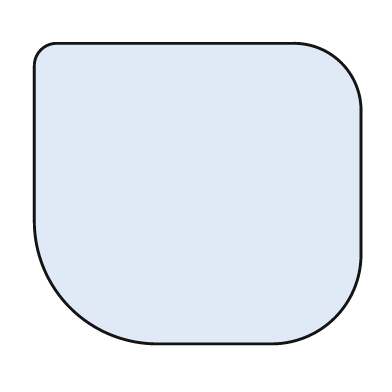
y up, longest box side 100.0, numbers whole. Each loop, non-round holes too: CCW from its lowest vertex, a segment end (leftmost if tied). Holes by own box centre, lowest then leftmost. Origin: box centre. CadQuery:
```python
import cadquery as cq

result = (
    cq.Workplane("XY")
    .moveTo(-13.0, -46.0)
    .lineTo(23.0, -46.0)
    .threePointArc((42.0, -38.0), (50.0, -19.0))
    .lineTo(50.0, 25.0)
    .threePointArc((44.0, 40.0), (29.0, 46.0))
    .lineTo(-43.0, 46.0)
    .threePointArc((-48.0, 44.0), (-50.0, 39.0))
    .lineTo(-50.0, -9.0)
    .threePointArc((-39.0, -35.0), (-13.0, -46.0))
    .close()
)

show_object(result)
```